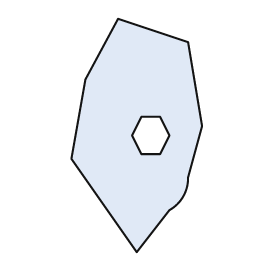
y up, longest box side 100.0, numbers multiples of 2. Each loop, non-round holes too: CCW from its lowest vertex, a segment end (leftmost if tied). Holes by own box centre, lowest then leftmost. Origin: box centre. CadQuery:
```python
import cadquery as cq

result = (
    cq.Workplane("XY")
    .moveTo(0.0, -50.0)
    .lineTo(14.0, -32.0)
    .threePointArc((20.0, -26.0), (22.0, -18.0))
    .lineTo(28.0, 4.0)
    .lineTo(22.0, 40.0)
    .lineTo(-8.0, 50.0)
    .lineTo(-22.0, 24.0)
    .lineTo(-28.0, -10.0)
    .close()
    .moveTo(2.0, -8.0)
    .lineTo(10.0, -8.0)
    .lineTo(14.0, 0.0)
    .lineTo(10.0, 8.0)
    .lineTo(2.0, 8.0)
    .lineTo(-2.0, 0.0)
    .close()
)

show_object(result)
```